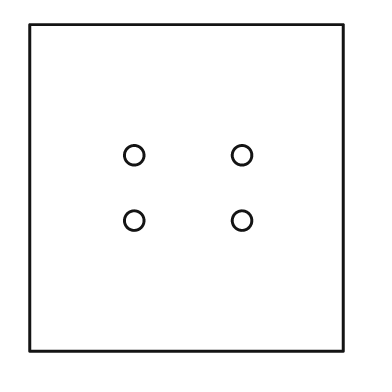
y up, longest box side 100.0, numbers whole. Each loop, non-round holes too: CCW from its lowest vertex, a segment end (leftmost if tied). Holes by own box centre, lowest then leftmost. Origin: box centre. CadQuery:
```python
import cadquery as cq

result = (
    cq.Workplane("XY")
    .moveTo(-48.0, -50.0)
    .lineTo(48.0, -50.0)
    .lineTo(48.0, 50.0)
    .lineTo(-48.0, 50.0)
    .close()
    .moveTo(-16.0, -10.0)
    .circle(3.0)
    .moveTo(17.0, -10.0)
    .circle(3.0)
    .moveTo(-16.0, 10.0)
    .circle(3.0)
    .moveTo(17.0, 10.0)
    .circle(3.0)
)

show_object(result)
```